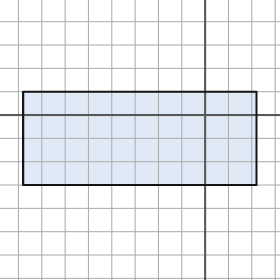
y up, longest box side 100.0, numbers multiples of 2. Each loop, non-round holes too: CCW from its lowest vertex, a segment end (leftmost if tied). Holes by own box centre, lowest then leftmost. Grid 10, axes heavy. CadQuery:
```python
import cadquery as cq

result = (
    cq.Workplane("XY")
    .moveTo(-78.0, -30.0)
    .lineTo(22.0, -30.0)
    .lineTo(22.0, 10.0)
    .lineTo(-78.0, 10.0)
    .close()
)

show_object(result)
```